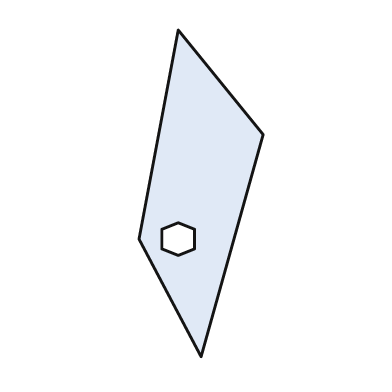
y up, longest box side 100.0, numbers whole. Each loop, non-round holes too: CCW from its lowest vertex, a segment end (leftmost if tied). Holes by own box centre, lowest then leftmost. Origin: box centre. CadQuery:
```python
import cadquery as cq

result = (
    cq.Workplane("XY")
    .moveTo(0.0, -50.0)
    .lineTo(19.0, 18.0)
    .lineTo(-7.0, 50.0)
    .lineTo(-19.0, -14.0)
    .close()
    .moveTo(-7.0, -19.0)
    .lineTo(-2.0, -17.0)
    .lineTo(-2.0, -11.0)
    .lineTo(-7.0, -9.0)
    .lineTo(-12.0, -11.0)
    .lineTo(-12.0, -17.0)
    .close()
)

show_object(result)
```